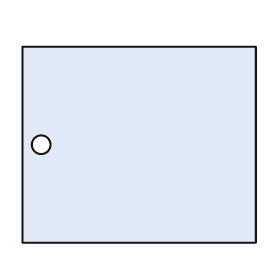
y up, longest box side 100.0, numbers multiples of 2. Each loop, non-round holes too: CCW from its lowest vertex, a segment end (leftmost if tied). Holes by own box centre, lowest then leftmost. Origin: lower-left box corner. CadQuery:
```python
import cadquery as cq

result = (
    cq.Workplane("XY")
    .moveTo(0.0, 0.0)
    .lineTo(100.0, 0.0)
    .lineTo(100.0, 84.0)
    .lineTo(0.0, 84.0)
    .close()
    .moveTo(8.0, 42.0)
    .circle(4.0)
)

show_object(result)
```